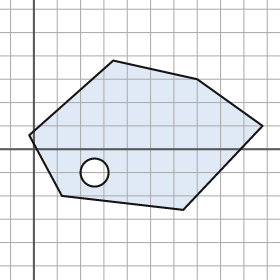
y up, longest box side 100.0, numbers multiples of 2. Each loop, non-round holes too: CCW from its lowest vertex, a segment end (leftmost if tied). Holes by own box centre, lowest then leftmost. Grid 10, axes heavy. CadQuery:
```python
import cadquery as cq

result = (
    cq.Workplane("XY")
    .moveTo(64.0, -26.0)
    .lineTo(98.0, 10.0)
    .lineTo(70.0, 30.0)
    .lineTo(34.0, 38.0)
    .lineTo(-2.0, 6.0)
    .lineTo(12.0, -20.0)
    .close()
    .moveTo(26.0, -10.0)
    .circle(6.0)
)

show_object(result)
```